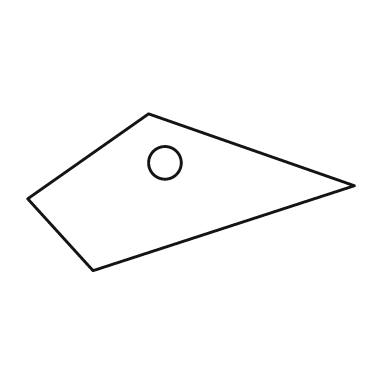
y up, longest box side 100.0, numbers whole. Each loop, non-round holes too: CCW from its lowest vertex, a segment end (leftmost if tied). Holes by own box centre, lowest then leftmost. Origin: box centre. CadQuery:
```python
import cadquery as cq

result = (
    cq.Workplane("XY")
    .moveTo(-30.0, -24.0)
    .lineTo(50.0, 2.0)
    .lineTo(-13.0, 24.0)
    .lineTo(-50.0, -2.0)
    .close()
    .moveTo(-8.0, 9.0)
    .circle(5.0)
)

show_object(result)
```